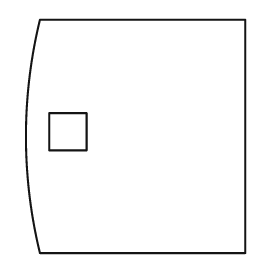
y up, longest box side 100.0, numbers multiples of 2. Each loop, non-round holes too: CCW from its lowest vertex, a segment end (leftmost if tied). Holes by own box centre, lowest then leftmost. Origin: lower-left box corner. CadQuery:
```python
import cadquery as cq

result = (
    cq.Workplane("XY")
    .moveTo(6.0, 0.0)
    .lineTo(94.0, 0.0)
    .lineTo(94.0, 100.0)
    .lineTo(6.0, 100.0)
    .threePointArc((0.0, 50.0), (6.0, 0.0))
    .close()
    .moveTo(10.0, 44.0)
    .lineTo(26.0, 44.0)
    .lineTo(26.0, 60.0)
    .lineTo(10.0, 60.0)
    .close()
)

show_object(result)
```